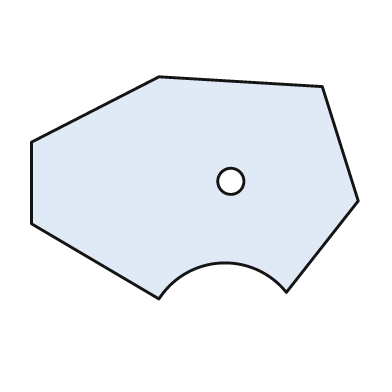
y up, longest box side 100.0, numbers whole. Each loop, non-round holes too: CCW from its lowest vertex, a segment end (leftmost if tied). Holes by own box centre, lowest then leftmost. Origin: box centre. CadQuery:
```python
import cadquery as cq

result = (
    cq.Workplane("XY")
    .moveTo(-11.0, -34.0)
    .threePointArc((8.0, -23.0), (28.0, -32.0))
    .lineTo(50.0, -4.0)
    .lineTo(39.0, 31.0)
    .lineTo(-11.0, 34.0)
    .lineTo(-50.0, 14.0)
    .lineTo(-50.0, -11.0)
    .close()
    .moveTo(11.0, 2.0)
    .circle(4.0)
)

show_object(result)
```